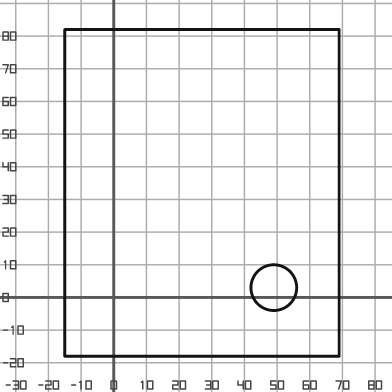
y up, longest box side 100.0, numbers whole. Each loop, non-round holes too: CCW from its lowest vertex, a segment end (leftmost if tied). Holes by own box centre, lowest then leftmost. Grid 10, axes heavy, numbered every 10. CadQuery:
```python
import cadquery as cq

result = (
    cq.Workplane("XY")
    .moveTo(-15.0, -18.0)
    .lineTo(69.0, -18.0)
    .lineTo(69.0, 82.0)
    .lineTo(-15.0, 82.0)
    .close()
    .moveTo(49.0, 3.0)
    .circle(7.0)
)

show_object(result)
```